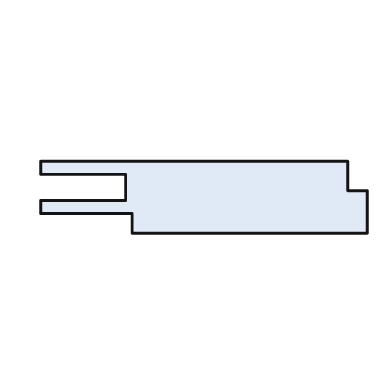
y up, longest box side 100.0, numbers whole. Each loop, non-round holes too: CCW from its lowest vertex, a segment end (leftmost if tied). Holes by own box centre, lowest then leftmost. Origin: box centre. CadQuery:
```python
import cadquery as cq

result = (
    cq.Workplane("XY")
    .moveTo(-22.0, -11.0)
    .lineTo(50.0, -11.0)
    .lineTo(50.0, 2.0)
    .lineTo(44.0, 2.0)
    .lineTo(44.0, 11.0)
    .lineTo(-50.0, 11.0)
    .lineTo(-50.0, 7.0)
    .lineTo(-24.0, 7.0)
    .lineTo(-24.0, -1.0)
    .lineTo(-50.0, -1.0)
    .lineTo(-50.0, -5.0)
    .lineTo(-22.0, -5.0)
    .close()
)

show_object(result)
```